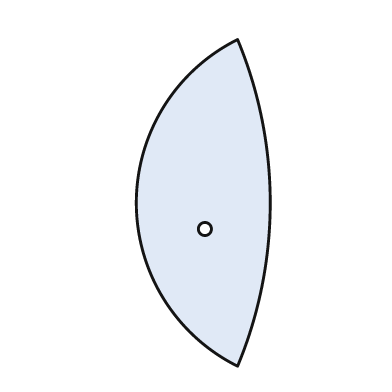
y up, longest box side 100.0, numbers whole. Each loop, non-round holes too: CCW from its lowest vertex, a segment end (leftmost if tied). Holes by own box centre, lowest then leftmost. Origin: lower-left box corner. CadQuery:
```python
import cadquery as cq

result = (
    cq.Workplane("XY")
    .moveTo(31.0, 0.0)
    .threePointArc((41.0, 50.0), (31.0, 100.0))
    .threePointArc((0.0, 50.0), (31.0, 0.0))
    .close()
    .moveTo(21.0, 42.0)
    .circle(2.0)
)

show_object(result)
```